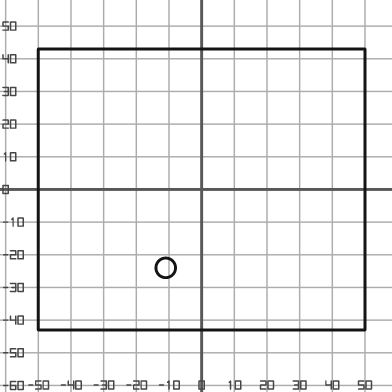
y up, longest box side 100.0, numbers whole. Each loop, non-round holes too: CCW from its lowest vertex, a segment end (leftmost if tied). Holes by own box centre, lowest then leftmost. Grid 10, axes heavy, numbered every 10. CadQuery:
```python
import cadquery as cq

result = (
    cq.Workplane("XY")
    .moveTo(-50.0, -43.0)
    .lineTo(50.0, -43.0)
    .lineTo(50.0, 43.0)
    .lineTo(-50.0, 43.0)
    .close()
    .moveTo(-11.0, -24.0)
    .circle(3.0)
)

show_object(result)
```